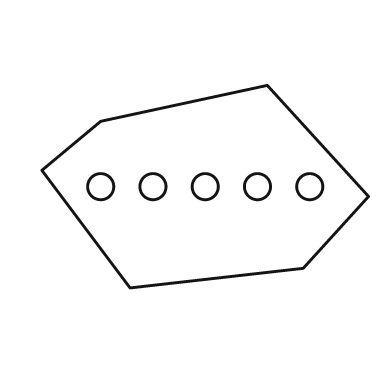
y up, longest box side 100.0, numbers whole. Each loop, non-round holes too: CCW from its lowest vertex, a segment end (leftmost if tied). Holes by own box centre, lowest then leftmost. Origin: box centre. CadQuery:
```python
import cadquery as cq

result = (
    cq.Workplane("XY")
    .moveTo(-23.0, -31.0)
    .lineTo(30.0, -25.0)
    .lineTo(50.0, -3.0)
    .lineTo(19.0, 31.0)
    .lineTo(-32.0, 20.0)
    .lineTo(-50.0, 5.0)
    .close()
    .moveTo(-32.0, 0.0)
    .circle(4.0)
    .moveTo(-16.0, 0.0)
    .circle(4.0)
    .moveTo(0.0, 0.0)
    .circle(4.0)
    .moveTo(16.0, 0.0)
    .circle(4.0)
    .moveTo(32.0, 0.0)
    .circle(4.0)
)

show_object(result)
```